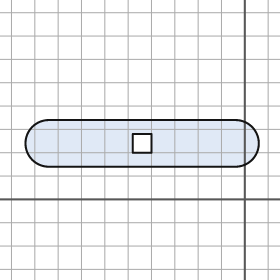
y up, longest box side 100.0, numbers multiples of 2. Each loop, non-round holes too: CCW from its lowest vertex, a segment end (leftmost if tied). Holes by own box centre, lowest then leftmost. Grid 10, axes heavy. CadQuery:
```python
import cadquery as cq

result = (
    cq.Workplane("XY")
    .moveTo(-84.0, 14.0)
    .lineTo(-4.0, 14.0)
    .threePointArc((6.0, 24.0), (-4.0, 34.0))
    .lineTo(-84.0, 34.0)
    .threePointArc((-94.0, 24.0), (-84.0, 14.0))
    .close()
    .moveTo(-48.0, 20.0)
    .lineTo(-40.0, 20.0)
    .lineTo(-40.0, 28.0)
    .lineTo(-48.0, 28.0)
    .close()
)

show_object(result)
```